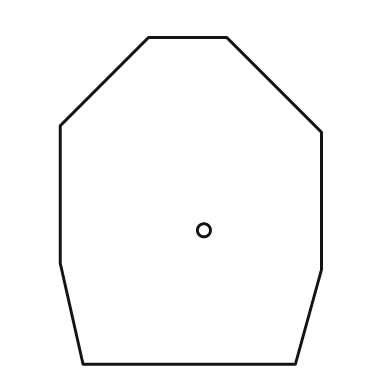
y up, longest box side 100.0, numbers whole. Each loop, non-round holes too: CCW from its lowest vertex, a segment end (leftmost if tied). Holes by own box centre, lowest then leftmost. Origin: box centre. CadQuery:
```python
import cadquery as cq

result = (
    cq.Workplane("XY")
    .moveTo(-33.0, -50.0)
    .lineTo(32.0, -50.0)
    .lineTo(40.0, -21.0)
    .lineTo(40.0, 21.0)
    .lineTo(11.0, 50.0)
    .lineTo(-13.0, 50.0)
    .lineTo(-40.0, 23.0)
    .lineTo(-40.0, -19.0)
    .close()
    .moveTo(4.0, -9.0)
    .circle(2.0)
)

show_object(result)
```